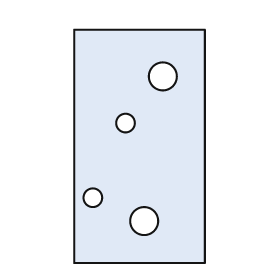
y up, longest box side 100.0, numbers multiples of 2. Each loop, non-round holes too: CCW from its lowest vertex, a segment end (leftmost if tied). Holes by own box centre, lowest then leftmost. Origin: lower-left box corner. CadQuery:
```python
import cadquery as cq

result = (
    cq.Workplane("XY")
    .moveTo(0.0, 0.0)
    .lineTo(56.0, 0.0)
    .lineTo(56.0, 100.0)
    .lineTo(0.0, 100.0)
    .close()
    .moveTo(30.0, 18.0)
    .circle(6.0)
    .moveTo(8.0, 28.0)
    .circle(4.0)
    .moveTo(22.0, 60.0)
    .circle(4.0)
    .moveTo(38.0, 80.0)
    .circle(6.0)
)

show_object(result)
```